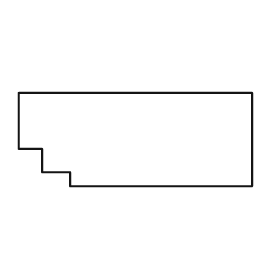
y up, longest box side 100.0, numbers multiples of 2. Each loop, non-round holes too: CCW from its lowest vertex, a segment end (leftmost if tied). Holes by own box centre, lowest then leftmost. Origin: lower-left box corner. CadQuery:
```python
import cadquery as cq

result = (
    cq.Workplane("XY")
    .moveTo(22.0, 0.0)
    .lineTo(100.0, 0.0)
    .lineTo(100.0, 40.0)
    .lineTo(0.0, 40.0)
    .lineTo(0.0, 16.0)
    .lineTo(10.0, 16.0)
    .lineTo(10.0, 6.0)
    .lineTo(22.0, 6.0)
    .close()
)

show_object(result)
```